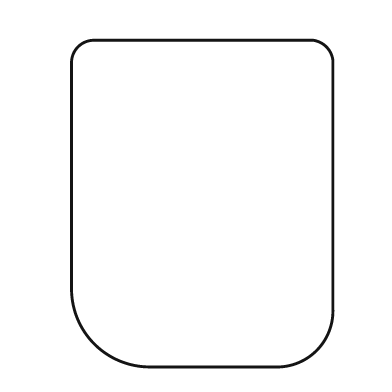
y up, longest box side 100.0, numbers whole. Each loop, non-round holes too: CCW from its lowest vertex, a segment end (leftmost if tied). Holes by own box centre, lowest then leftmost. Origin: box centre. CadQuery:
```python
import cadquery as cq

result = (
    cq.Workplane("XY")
    .moveTo(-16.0, -50.0)
    .lineTo(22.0, -50.0)
    .threePointArc((35.0, -45.0), (40.0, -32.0))
    .lineTo(40.0, 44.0)
    .threePointArc((38.0, 48.0), (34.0, 50.0))
    .lineTo(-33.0, 50.0)
    .threePointArc((-38.0, 48.0), (-40.0, 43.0))
    .lineTo(-40.0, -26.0)
    .threePointArc((-33.0, -43.0), (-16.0, -50.0))
    .close()
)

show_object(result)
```